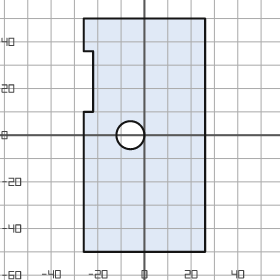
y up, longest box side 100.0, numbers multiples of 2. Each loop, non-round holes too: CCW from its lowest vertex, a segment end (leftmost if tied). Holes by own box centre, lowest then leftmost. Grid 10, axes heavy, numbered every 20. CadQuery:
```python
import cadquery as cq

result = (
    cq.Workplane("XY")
    .moveTo(-26.0, -50.0)
    .lineTo(26.0, -50.0)
    .lineTo(26.0, 50.0)
    .lineTo(-26.0, 50.0)
    .lineTo(-26.0, 36.0)
    .lineTo(-22.0, 36.0)
    .lineTo(-22.0, 10.0)
    .lineTo(-26.0, 10.0)
    .close()
    .moveTo(-6.0, 0.0)
    .circle(6.0)
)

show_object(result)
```